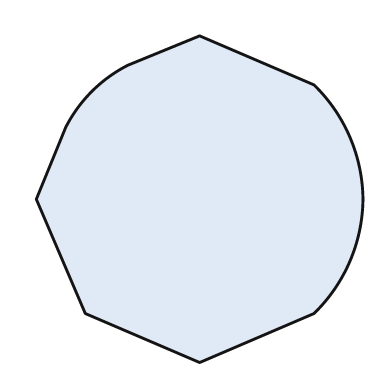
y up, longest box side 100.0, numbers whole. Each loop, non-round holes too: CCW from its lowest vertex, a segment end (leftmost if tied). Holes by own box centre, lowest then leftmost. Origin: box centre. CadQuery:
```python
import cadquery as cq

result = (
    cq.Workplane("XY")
    .moveTo(0.0, -50.0)
    .lineTo(35.0, -35.0)
    .threePointArc((46.0, -19.0), (50.0, 0.0))
    .threePointArc((46.0, 19.0), (35.0, 35.0))
    .lineTo(0.0, 50.0)
    .lineTo(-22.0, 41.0)
    .threePointArc((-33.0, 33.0), (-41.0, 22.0))
    .lineTo(-50.0, 0.0)
    .lineTo(-35.0, -35.0)
    .close()
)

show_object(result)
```